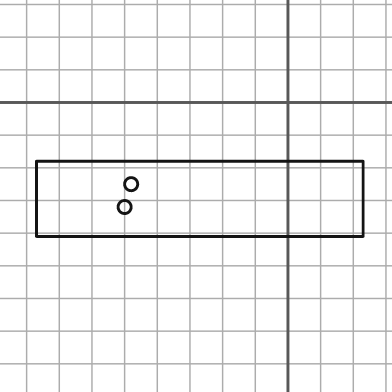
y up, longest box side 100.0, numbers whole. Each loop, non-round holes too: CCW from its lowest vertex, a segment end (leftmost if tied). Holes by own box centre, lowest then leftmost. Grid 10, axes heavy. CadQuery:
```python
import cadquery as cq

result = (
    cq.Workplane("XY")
    .moveTo(-77.0, -41.0)
    .lineTo(23.0, -41.0)
    .lineTo(23.0, -18.0)
    .lineTo(-77.0, -18.0)
    .close()
    .moveTo(-50.0, -32.0)
    .circle(2.0)
    .moveTo(-48.0, -25.0)
    .circle(2.0)
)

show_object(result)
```